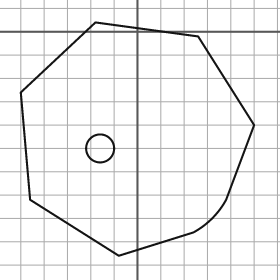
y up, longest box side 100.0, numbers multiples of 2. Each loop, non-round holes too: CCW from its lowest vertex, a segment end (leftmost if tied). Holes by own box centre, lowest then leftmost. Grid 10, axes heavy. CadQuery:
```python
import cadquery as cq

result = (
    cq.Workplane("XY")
    .moveTo(-8.0, -96.0)
    .lineTo(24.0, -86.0)
    .threePointArc((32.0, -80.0), (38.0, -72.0))
    .lineTo(50.0, -40.0)
    .lineTo(26.0, -2.0)
    .lineTo(-18.0, 4.0)
    .lineTo(-50.0, -26.0)
    .lineTo(-46.0, -72.0)
    .close()
    .moveTo(-16.0, -50.0)
    .circle(6.0)
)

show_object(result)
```